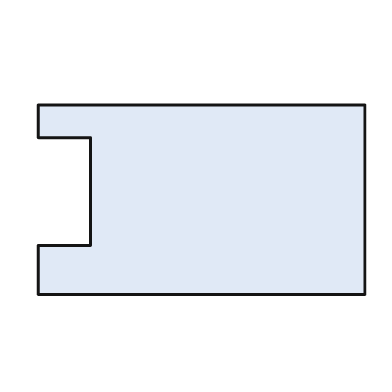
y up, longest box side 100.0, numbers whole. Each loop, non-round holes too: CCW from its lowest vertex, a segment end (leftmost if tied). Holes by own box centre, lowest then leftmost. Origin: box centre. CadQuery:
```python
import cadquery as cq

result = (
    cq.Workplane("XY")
    .moveTo(-50.0, -29.0)
    .lineTo(50.0, -29.0)
    .lineTo(50.0, 29.0)
    .lineTo(-50.0, 29.0)
    .lineTo(-50.0, 19.0)
    .lineTo(-34.0, 19.0)
    .lineTo(-34.0, -14.0)
    .lineTo(-50.0, -14.0)
    .close()
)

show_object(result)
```